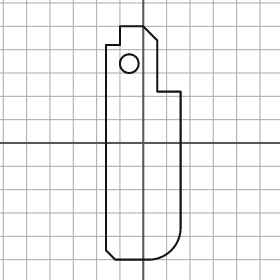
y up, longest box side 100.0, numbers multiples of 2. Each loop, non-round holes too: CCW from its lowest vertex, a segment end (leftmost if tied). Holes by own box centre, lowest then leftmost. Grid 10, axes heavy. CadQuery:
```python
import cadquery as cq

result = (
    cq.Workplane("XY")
    .moveTo(-12.0, -50.0)
    .lineTo(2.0, -50.0)
    .threePointArc((12.0, -46.0), (16.0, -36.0))
    .lineTo(16.0, 22.0)
    .lineTo(6.0, 22.0)
    .lineTo(6.0, 44.0)
    .lineTo(0.0, 50.0)
    .lineTo(-10.0, 50.0)
    .lineTo(-10.0, 42.0)
    .lineTo(-16.0, 42.0)
    .lineTo(-16.0, -46.0)
    .close()
    .moveTo(-6.0, 34.0)
    .circle(4.0)
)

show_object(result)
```